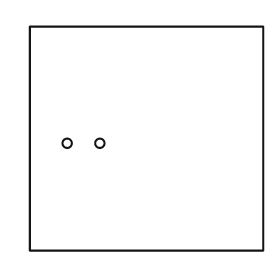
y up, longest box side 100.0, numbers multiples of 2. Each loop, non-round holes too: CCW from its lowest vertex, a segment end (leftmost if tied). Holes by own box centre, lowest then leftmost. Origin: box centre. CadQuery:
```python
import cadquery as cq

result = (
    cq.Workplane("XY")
    .moveTo(-50.0, -48.0)
    .lineTo(50.0, -48.0)
    .lineTo(50.0, 48.0)
    .lineTo(-50.0, 48.0)
    .close()
    .moveTo(-34.0, -2.0)
    .circle(2.0)
    .moveTo(-20.0, -2.0)
    .circle(2.0)
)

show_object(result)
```